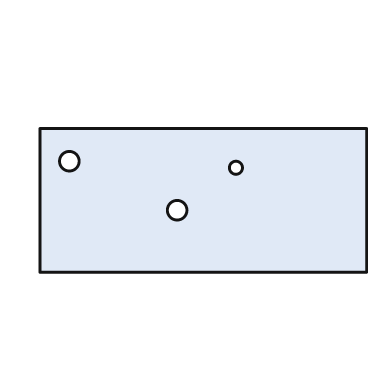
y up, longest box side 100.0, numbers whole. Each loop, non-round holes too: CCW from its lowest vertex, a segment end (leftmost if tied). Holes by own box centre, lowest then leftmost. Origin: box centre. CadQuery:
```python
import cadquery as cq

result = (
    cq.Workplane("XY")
    .moveTo(-50.0, -22.0)
    .lineTo(50.0, -22.0)
    .lineTo(50.0, 22.0)
    .lineTo(-50.0, 22.0)
    .close()
    .moveTo(-8.0, -3.0)
    .circle(3.0)
    .moveTo(10.0, 10.0)
    .circle(2.0)
    .moveTo(-41.0, 12.0)
    .circle(3.0)
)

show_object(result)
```